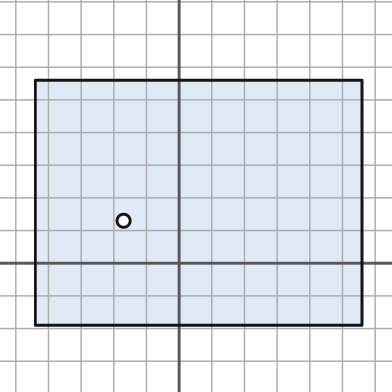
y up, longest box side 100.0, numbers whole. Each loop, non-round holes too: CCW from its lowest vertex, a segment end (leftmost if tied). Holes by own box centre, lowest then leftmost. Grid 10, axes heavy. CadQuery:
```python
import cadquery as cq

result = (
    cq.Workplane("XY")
    .moveTo(-44.0, -19.0)
    .lineTo(56.0, -19.0)
    .lineTo(56.0, 56.0)
    .lineTo(-44.0, 56.0)
    .close()
    .moveTo(-17.0, 13.0)
    .circle(2.0)
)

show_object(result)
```